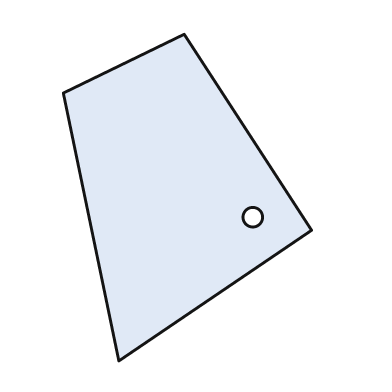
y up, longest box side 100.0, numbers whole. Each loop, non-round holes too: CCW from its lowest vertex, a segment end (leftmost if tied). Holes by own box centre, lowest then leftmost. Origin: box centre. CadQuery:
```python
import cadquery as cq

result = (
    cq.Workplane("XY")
    .moveTo(-21.0, -50.0)
    .lineTo(38.0, -10.0)
    .lineTo(-1.0, 50.0)
    .lineTo(-38.0, 32.0)
    .close()
    .moveTo(20.0, -6.0)
    .circle(3.0)
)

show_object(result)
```